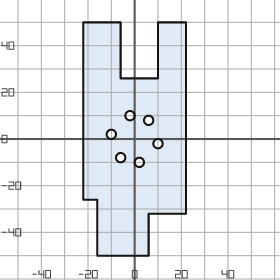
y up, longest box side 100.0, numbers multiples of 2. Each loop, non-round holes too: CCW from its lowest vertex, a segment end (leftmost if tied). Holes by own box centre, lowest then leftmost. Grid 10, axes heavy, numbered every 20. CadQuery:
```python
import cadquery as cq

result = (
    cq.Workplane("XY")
    .moveTo(-16.0, -50.0)
    .lineTo(6.0, -50.0)
    .lineTo(6.0, -32.0)
    .lineTo(22.0, -32.0)
    .lineTo(22.0, 50.0)
    .lineTo(10.0, 50.0)
    .lineTo(10.0, 26.0)
    .lineTo(-6.0, 26.0)
    .lineTo(-6.0, 50.0)
    .lineTo(-22.0, 50.0)
    .lineTo(-22.0, -26.0)
    .lineTo(-16.0, -26.0)
    .close()
    .moveTo(2.0, -10.0)
    .circle(2.0)
    .moveTo(-6.0, -8.0)
    .circle(2.0)
    .moveTo(10.0, -2.0)
    .circle(2.0)
    .moveTo(-10.0, 2.0)
    .circle(2.0)
    .moveTo(6.0, 8.0)
    .circle(2.0)
    .moveTo(-2.0, 10.0)
    .circle(2.0)
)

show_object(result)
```